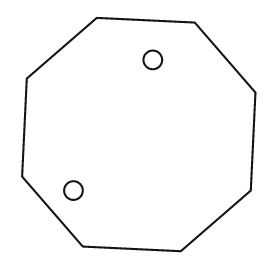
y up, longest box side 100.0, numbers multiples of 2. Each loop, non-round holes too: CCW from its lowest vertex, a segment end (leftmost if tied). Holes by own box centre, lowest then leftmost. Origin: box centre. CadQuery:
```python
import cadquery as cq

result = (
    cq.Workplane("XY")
    .moveTo(18.0, -50.0)
    .lineTo(48.0, -24.0)
    .lineTo(50.0, 18.0)
    .lineTo(24.0, 48.0)
    .lineTo(-18.0, 50.0)
    .lineTo(-48.0, 24.0)
    .lineTo(-50.0, -18.0)
    .lineTo(-24.0, -48.0)
    .close()
    .moveTo(-28.0, -24.0)
    .circle(4.0)
    .moveTo(6.0, 32.0)
    .circle(4.0)
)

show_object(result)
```